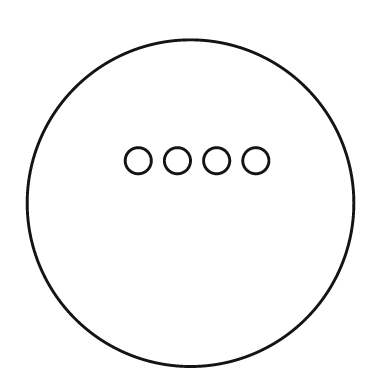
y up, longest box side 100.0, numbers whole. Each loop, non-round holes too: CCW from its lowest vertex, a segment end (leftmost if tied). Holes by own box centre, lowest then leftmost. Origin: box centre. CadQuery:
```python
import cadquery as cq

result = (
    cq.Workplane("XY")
    .moveTo(0.0, 0.0)
    .circle(50.0)
    .moveTo(-16.0, 13.0)
    .circle(4.0)
    .moveTo(-4.0, 13.0)
    .circle(4.0)
    .moveTo(8.0, 13.0)
    .circle(4.0)
    .moveTo(20.0, 13.0)
    .circle(4.0)
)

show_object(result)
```